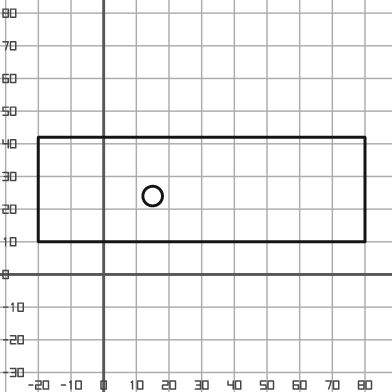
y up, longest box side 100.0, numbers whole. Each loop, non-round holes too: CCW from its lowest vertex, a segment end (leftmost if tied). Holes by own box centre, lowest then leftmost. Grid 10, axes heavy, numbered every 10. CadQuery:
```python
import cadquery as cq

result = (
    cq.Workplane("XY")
    .moveTo(-20.0, 10.0)
    .lineTo(80.0, 10.0)
    .lineTo(80.0, 42.0)
    .lineTo(-20.0, 42.0)
    .close()
    .moveTo(15.0, 24.0)
    .circle(3.0)
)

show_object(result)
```